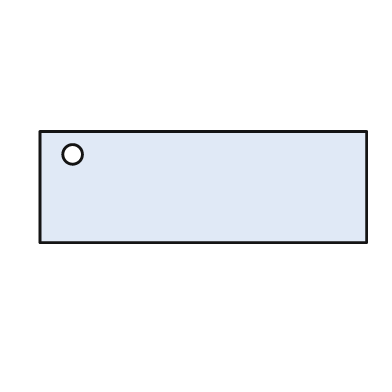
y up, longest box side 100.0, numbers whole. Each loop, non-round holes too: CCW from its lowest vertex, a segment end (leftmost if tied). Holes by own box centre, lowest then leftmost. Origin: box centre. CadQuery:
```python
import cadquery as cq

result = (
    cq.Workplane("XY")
    .moveTo(-50.0, -17.0)
    .lineTo(50.0, -17.0)
    .lineTo(50.0, 17.0)
    .lineTo(-50.0, 17.0)
    .close()
    .moveTo(-40.0, 10.0)
    .circle(3.0)
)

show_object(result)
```